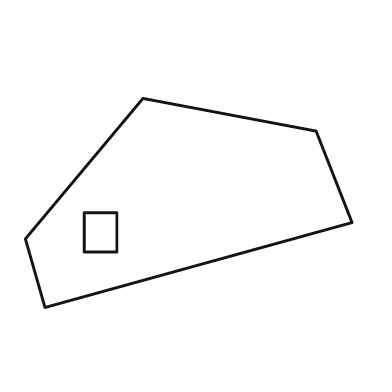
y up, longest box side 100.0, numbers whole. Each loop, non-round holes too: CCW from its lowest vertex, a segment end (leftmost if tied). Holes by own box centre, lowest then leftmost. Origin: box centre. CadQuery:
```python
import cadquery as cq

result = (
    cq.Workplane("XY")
    .moveTo(-44.0, -32.0)
    .lineTo(50.0, -6.0)
    .lineTo(39.0, 22.0)
    .lineTo(-14.0, 32.0)
    .lineTo(-50.0, -11.0)
    .close()
    .moveTo(-32.0, -15.0)
    .lineTo(-22.0, -15.0)
    .lineTo(-22.0, -3.0)
    .lineTo(-32.0, -3.0)
    .close()
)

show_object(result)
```